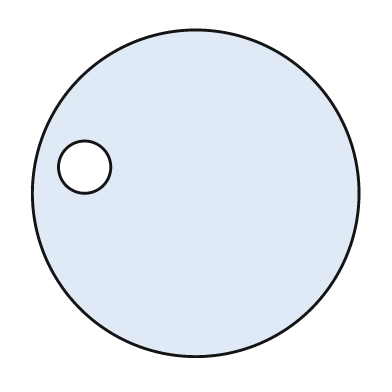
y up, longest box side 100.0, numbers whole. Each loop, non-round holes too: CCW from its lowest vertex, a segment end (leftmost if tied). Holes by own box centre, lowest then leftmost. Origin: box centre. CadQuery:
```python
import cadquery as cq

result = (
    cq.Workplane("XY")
    .moveTo(0.0, 0.0)
    .circle(50.0)
    .moveTo(-34.0, 8.0)
    .circle(8.0)
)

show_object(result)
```